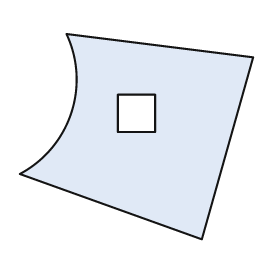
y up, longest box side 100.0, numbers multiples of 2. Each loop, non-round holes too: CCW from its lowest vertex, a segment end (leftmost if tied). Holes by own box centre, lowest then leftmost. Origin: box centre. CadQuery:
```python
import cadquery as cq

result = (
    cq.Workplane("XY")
    .moveTo(28.0, -44.0)
    .lineTo(50.0, 34.0)
    .lineTo(-30.0, 44.0)
    .threePointArc((-28.0, 10.0), (-50.0, -16.0))
    .close()
    .moveTo(-8.0, 2.0)
    .lineTo(8.0, 2.0)
    .lineTo(8.0, 18.0)
    .lineTo(-8.0, 18.0)
    .close()
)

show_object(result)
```